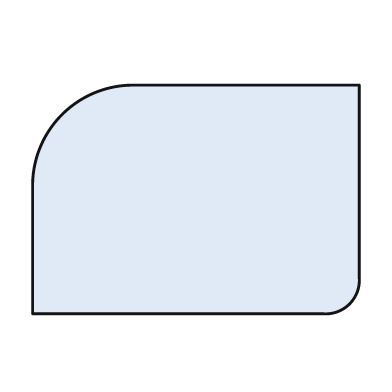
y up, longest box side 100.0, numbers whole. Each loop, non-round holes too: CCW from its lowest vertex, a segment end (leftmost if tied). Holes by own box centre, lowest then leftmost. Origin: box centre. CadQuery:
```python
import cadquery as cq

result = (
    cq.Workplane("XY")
    .moveTo(-50.0, -35.0)
    .lineTo(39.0, -35.0)
    .threePointArc((47.0, -32.0), (50.0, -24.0))
    .lineTo(50.0, 35.0)
    .lineTo(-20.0, 35.0)
    .threePointArc((-41.0, 26.0), (-50.0, 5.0))
    .close()
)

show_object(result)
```